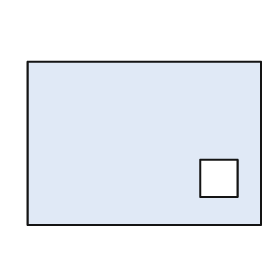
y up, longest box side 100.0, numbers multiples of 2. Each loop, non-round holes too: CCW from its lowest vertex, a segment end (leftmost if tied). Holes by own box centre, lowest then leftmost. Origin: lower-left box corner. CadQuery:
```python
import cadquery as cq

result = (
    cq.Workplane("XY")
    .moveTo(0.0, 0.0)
    .lineTo(100.0, 0.0)
    .lineTo(100.0, 70.0)
    .lineTo(0.0, 70.0)
    .close()
    .moveTo(74.0, 12.0)
    .lineTo(90.0, 12.0)
    .lineTo(90.0, 28.0)
    .lineTo(74.0, 28.0)
    .close()
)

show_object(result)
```